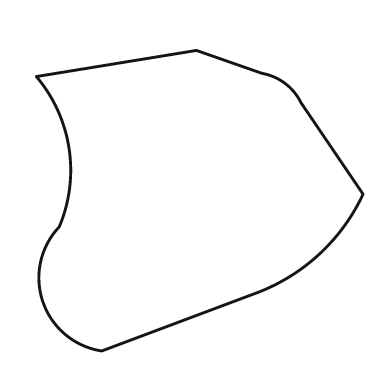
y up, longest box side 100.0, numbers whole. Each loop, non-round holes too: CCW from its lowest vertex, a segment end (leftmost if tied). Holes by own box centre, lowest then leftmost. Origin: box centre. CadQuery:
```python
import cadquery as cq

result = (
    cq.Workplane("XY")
    .moveTo(-30.0, -46.0)
    .lineTo(18.0, -28.0)
    .threePointArc((37.0, -16.0), (50.0, 2.0))
    .lineTo(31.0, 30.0)
    .threePointArc((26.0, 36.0), (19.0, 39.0))
    .lineTo(-1.0, 46.0)
    .lineTo(-50.0, 38.0)
    .threePointArc((-40.0, 16.0), (-43.0, -8.0))
    .threePointArc((-48.0, -31.0), (-30.0, -46.0))
    .close()
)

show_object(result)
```